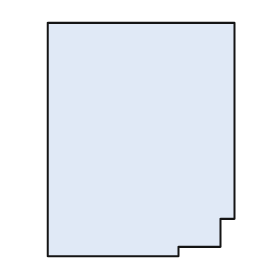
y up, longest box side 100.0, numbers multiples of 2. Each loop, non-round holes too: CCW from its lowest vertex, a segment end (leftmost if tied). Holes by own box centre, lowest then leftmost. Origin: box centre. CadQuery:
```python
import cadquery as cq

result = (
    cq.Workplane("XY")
    .moveTo(-40.0, -50.0)
    .lineTo(16.0, -50.0)
    .lineTo(16.0, -46.0)
    .lineTo(34.0, -46.0)
    .lineTo(34.0, -34.0)
    .lineTo(40.0, -34.0)
    .lineTo(40.0, 50.0)
    .lineTo(-40.0, 50.0)
    .close()
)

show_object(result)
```